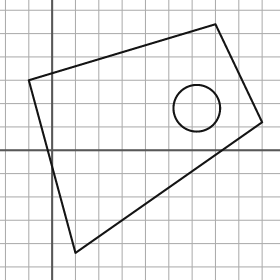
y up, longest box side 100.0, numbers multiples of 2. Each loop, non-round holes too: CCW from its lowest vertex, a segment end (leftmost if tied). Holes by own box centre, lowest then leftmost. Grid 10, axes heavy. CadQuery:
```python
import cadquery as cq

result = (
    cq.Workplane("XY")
    .moveTo(10.0, -44.0)
    .lineTo(90.0, 12.0)
    .lineTo(70.0, 54.0)
    .lineTo(-10.0, 30.0)
    .close()
    .moveTo(62.0, 18.0)
    .circle(10.0)
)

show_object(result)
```